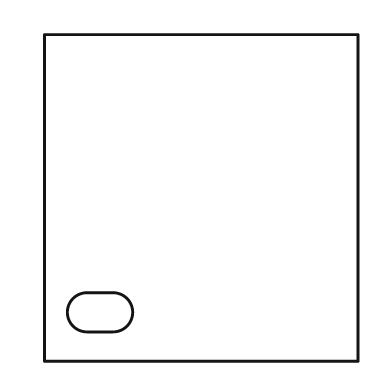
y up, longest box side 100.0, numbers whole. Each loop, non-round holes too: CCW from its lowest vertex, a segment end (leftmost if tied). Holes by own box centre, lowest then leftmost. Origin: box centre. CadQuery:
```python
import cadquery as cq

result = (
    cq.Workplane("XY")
    .moveTo(-48.0, -50.0)
    .lineTo(48.0, -50.0)
    .lineTo(48.0, 50.0)
    .lineTo(-48.0, 50.0)
    .close()
    .moveTo(-35.0, -41.0)
    .lineTo(-27.0, -41.0)
    .threePointArc((-21.0, -35.0), (-27.0, -29.0))
    .lineTo(-35.0, -29.0)
    .threePointArc((-41.0, -35.0), (-35.0, -41.0))
    .close()
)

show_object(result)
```